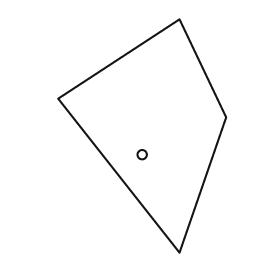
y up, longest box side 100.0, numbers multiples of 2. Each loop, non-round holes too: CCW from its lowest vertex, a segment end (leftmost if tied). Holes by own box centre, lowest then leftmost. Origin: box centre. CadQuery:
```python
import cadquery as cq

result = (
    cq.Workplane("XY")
    .moveTo(16.0, -50.0)
    .lineTo(36.0, 8.0)
    .lineTo(16.0, 50.0)
    .lineTo(-36.0, 16.0)
    .close()
    .moveTo(0.0, -8.0)
    .circle(2.0)
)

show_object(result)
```